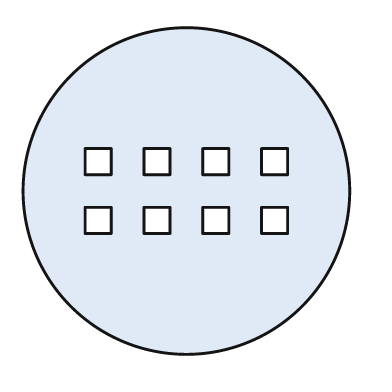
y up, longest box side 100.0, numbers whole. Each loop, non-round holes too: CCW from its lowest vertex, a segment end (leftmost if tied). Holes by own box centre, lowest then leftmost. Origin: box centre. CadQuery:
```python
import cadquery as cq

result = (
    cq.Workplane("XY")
    .moveTo(0.0, 0.0)
    .circle(50.0)
    .moveTo(-31.0, -13.0)
    .lineTo(-23.0, -13.0)
    .lineTo(-23.0, -5.0)
    .lineTo(-31.0, -5.0)
    .close()
    .moveTo(-13.0, -13.0)
    .lineTo(-5.0, -13.0)
    .lineTo(-5.0, -5.0)
    .lineTo(-13.0, -5.0)
    .close()
    .moveTo(5.0, -13.0)
    .lineTo(13.0, -13.0)
    .lineTo(13.0, -5.0)
    .lineTo(5.0, -5.0)
    .close()
    .moveTo(23.0, -13.0)
    .lineTo(31.0, -13.0)
    .lineTo(31.0, -5.0)
    .lineTo(23.0, -5.0)
    .close()
    .moveTo(-31.0, 5.0)
    .lineTo(-23.0, 5.0)
    .lineTo(-23.0, 13.0)
    .lineTo(-31.0, 13.0)
    .close()
    .moveTo(-13.0, 5.0)
    .lineTo(-5.0, 5.0)
    .lineTo(-5.0, 13.0)
    .lineTo(-13.0, 13.0)
    .close()
    .moveTo(5.0, 5.0)
    .lineTo(13.0, 5.0)
    .lineTo(13.0, 13.0)
    .lineTo(5.0, 13.0)
    .close()
    .moveTo(23.0, 5.0)
    .lineTo(31.0, 5.0)
    .lineTo(31.0, 13.0)
    .lineTo(23.0, 13.0)
    .close()
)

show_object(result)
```